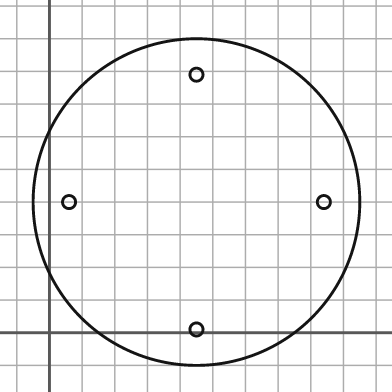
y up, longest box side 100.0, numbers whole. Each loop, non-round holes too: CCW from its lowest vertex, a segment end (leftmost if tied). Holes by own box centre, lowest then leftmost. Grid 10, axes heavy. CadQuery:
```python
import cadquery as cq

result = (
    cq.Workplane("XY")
    .moveTo(45.0, 40.0)
    .circle(50.0)
    .moveTo(45.0, 1.0)
    .circle(2.0)
    .moveTo(6.0, 40.0)
    .circle(2.0)
    .moveTo(84.0, 40.0)
    .circle(2.0)
    .moveTo(45.0, 79.0)
    .circle(2.0)
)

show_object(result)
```